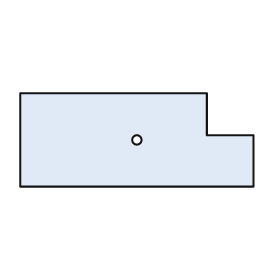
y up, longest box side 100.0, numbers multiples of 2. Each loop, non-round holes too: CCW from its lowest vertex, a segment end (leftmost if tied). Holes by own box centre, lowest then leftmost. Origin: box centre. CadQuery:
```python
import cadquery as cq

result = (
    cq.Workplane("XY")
    .moveTo(-50.0, -20.0)
    .lineTo(50.0, -20.0)
    .lineTo(50.0, 2.0)
    .lineTo(30.0, 2.0)
    .lineTo(30.0, 20.0)
    .lineTo(-50.0, 20.0)
    .close()
    .moveTo(0.0, 0.0)
    .circle(2.0)
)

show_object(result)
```